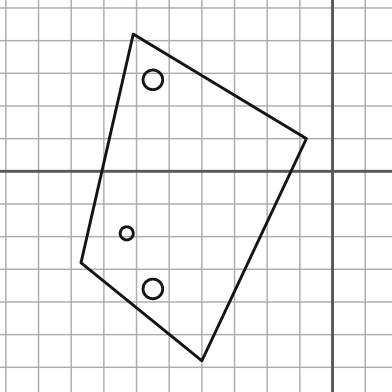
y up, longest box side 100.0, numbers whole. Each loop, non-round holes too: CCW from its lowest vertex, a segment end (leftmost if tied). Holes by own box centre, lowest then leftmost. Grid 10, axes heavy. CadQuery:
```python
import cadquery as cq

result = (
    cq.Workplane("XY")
    .moveTo(-40.0, -58.0)
    .lineTo(-8.0, 10.0)
    .lineTo(-61.0, 42.0)
    .lineTo(-77.0, -28.0)
    .close()
    .moveTo(-55.0, -36.0)
    .circle(3.0)
    .moveTo(-63.0, -19.0)
    .circle(2.0)
    .moveTo(-55.0, 28.0)
    .circle(3.0)
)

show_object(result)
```